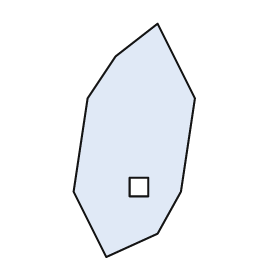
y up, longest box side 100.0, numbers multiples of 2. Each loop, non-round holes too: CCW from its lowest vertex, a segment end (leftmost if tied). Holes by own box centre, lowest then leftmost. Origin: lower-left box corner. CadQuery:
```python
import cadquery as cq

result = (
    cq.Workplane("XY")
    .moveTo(14.0, 0.0)
    .lineTo(36.0, 10.0)
    .lineTo(46.0, 28.0)
    .lineTo(52.0, 68.0)
    .lineTo(36.0, 100.0)
    .lineTo(18.0, 86.0)
    .lineTo(6.0, 68.0)
    .lineTo(0.0, 28.0)
    .close()
    .moveTo(24.0, 26.0)
    .lineTo(32.0, 26.0)
    .lineTo(32.0, 34.0)
    .lineTo(24.0, 34.0)
    .close()
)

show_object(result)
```